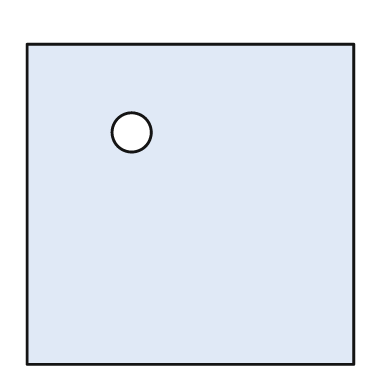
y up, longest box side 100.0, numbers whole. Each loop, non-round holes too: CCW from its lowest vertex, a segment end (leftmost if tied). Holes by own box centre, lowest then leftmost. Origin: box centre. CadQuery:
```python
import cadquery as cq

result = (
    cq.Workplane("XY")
    .moveTo(-50.0, -49.0)
    .lineTo(50.0, -49.0)
    .lineTo(50.0, 49.0)
    .lineTo(-50.0, 49.0)
    .close()
    .moveTo(-18.0, 22.0)
    .circle(6.0)
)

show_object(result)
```